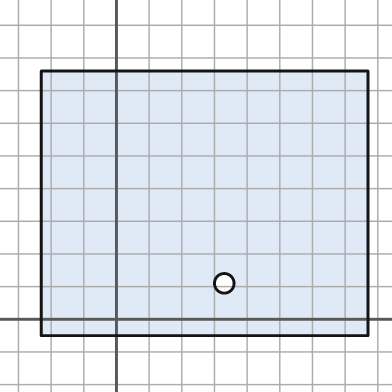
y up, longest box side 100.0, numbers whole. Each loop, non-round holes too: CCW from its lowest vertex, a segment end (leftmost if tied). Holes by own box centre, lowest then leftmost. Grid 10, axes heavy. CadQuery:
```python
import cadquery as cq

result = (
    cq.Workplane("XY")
    .moveTo(-23.0, -5.0)
    .lineTo(77.0, -5.0)
    .lineTo(77.0, 76.0)
    .lineTo(-23.0, 76.0)
    .close()
    .moveTo(33.0, 11.0)
    .circle(3.0)
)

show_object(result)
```